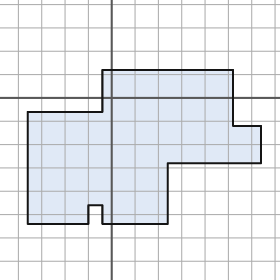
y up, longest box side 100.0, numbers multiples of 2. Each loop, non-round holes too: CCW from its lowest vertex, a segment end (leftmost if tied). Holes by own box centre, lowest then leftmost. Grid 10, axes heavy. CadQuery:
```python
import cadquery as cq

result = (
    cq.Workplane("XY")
    .moveTo(-36.0, -54.0)
    .lineTo(-10.0, -54.0)
    .lineTo(-10.0, -46.0)
    .lineTo(-4.0, -46.0)
    .lineTo(-4.0, -54.0)
    .lineTo(24.0, -54.0)
    .lineTo(24.0, -28.0)
    .lineTo(64.0, -28.0)
    .lineTo(64.0, -12.0)
    .lineTo(52.0, -12.0)
    .lineTo(52.0, 12.0)
    .lineTo(-4.0, 12.0)
    .lineTo(-4.0, -6.0)
    .lineTo(-36.0, -6.0)
    .close()
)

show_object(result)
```